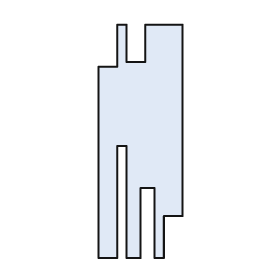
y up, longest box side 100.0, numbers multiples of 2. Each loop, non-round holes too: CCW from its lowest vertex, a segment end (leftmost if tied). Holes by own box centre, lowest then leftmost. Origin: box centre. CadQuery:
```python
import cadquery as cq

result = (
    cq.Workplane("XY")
    .moveTo(-18.0, -50.0)
    .lineTo(-10.0, -50.0)
    .lineTo(-10.0, -2.0)
    .lineTo(-6.0, -2.0)
    .lineTo(-6.0, -50.0)
    .lineTo(0.0, -50.0)
    .lineTo(0.0, -20.0)
    .lineTo(6.0, -20.0)
    .lineTo(6.0, -50.0)
    .lineTo(10.0, -50.0)
    .lineTo(10.0, -32.0)
    .lineTo(18.0, -32.0)
    .lineTo(18.0, 50.0)
    .lineTo(2.0, 50.0)
    .lineTo(2.0, 34.0)
    .lineTo(-6.0, 34.0)
    .lineTo(-6.0, 50.0)
    .lineTo(-10.0, 50.0)
    .lineTo(-10.0, 32.0)
    .lineTo(-18.0, 32.0)
    .close()
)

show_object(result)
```